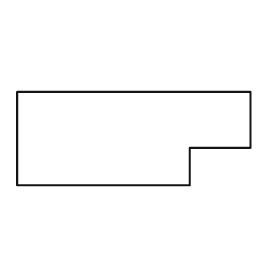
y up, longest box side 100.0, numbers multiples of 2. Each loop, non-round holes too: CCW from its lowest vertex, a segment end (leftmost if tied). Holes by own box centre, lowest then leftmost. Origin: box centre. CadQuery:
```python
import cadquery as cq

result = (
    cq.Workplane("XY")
    .moveTo(-50.0, -20.0)
    .lineTo(24.0, -20.0)
    .lineTo(24.0, -4.0)
    .lineTo(50.0, -4.0)
    .lineTo(50.0, 20.0)
    .lineTo(-50.0, 20.0)
    .close()
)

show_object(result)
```